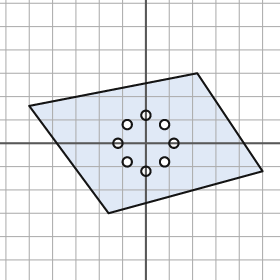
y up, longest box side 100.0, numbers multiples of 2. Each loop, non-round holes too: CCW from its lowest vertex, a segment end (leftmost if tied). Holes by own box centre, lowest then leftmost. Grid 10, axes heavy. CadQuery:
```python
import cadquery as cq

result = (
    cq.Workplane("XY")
    .moveTo(-16.0, -30.0)
    .lineTo(50.0, -12.0)
    .lineTo(22.0, 30.0)
    .lineTo(-50.0, 16.0)
    .close()
    .moveTo(0.0, -12.0)
    .circle(2.0)
    .moveTo(-8.0, -8.0)
    .circle(2.0)
    .moveTo(8.0, -8.0)
    .circle(2.0)
    .moveTo(-12.0, 0.0)
    .circle(2.0)
    .moveTo(12.0, 0.0)
    .circle(2.0)
    .moveTo(-8.0, 8.0)
    .circle(2.0)
    .moveTo(8.0, 8.0)
    .circle(2.0)
    .moveTo(0.0, 12.0)
    .circle(2.0)
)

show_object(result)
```